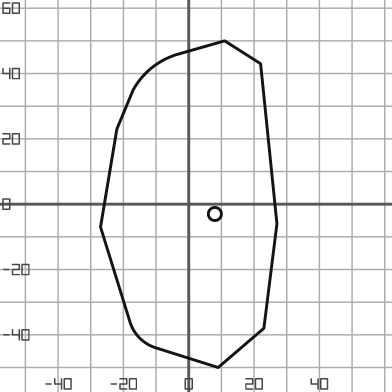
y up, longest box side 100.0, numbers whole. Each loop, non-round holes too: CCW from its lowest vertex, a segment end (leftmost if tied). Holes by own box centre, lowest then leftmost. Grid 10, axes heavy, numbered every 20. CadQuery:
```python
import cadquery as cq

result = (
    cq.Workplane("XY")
    .moveTo(9.0, -50.0)
    .lineTo(23.0, -38.0)
    .lineTo(27.0, -6.0)
    .lineTo(22.0, 43.0)
    .lineTo(11.0, 50.0)
    .lineTo(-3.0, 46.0)
    .threePointArc((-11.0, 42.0), (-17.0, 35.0))
    .lineTo(-22.0, 23.0)
    .lineTo(-27.0, -7.0)
    .lineTo(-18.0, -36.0)
    .threePointArc((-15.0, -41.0), (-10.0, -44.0))
    .close()
    .moveTo(8.0, -3.0)
    .circle(2.0)
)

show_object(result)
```